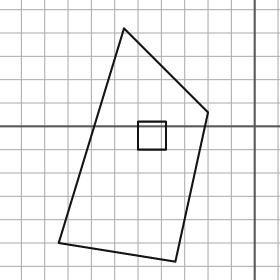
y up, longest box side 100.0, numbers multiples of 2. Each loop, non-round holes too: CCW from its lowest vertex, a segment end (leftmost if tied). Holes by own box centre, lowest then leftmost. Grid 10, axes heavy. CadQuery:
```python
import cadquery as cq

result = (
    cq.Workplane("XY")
    .moveTo(-34.0, -58.0)
    .lineTo(-20.0, 6.0)
    .lineTo(-56.0, 42.0)
    .lineTo(-84.0, -50.0)
    .close()
    .moveTo(-50.0, -10.0)
    .lineTo(-38.0, -10.0)
    .lineTo(-38.0, 2.0)
    .lineTo(-50.0, 2.0)
    .close()
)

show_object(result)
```